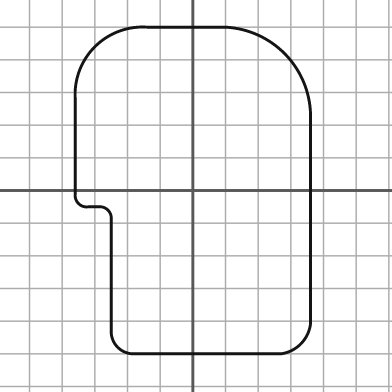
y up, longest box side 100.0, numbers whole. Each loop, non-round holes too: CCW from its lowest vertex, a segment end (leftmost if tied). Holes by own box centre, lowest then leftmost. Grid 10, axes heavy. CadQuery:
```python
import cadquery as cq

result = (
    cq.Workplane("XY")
    .moveTo(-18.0, -50.0)
    .lineTo(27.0, -50.0)
    .threePointArc((33.0, -47.0), (36.0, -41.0))
    .lineTo(36.0, 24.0)
    .threePointArc((28.0, 42.0), (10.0, 50.0))
    .lineTo(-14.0, 50.0)
    .threePointArc((-30.0, 44.0), (-36.0, 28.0))
    .lineTo(-36.0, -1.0)
    .threePointArc((-35.0, -4.0), (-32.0, -5.0))
    .lineTo(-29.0, -5.0)
    .threePointArc((-26.0, -6.0), (-25.0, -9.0))
    .lineTo(-25.0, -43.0)
    .threePointArc((-23.0, -48.0), (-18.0, -50.0))
    .close()
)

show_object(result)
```